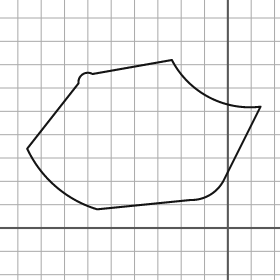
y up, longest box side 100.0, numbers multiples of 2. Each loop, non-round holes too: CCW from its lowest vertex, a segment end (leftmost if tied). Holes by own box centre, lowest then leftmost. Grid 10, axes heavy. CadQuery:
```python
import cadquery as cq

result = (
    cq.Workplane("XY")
    .moveTo(-56.0, 8.0)
    .lineTo(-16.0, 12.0)
    .threePointArc((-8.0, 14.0), (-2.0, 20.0))
    .lineTo(14.0, 52.0)
    .threePointArc((-8.0, 56.0), (-24.0, 72.0))
    .lineTo(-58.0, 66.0)
    .threePointArc((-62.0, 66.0), (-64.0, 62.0))
    .lineTo(-86.0, 34.0)
    .threePointArc((-74.0, 18.0), (-56.0, 8.0))
    .close()
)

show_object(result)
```